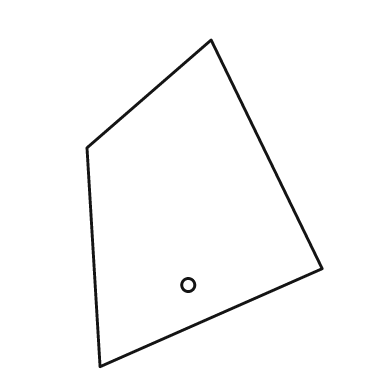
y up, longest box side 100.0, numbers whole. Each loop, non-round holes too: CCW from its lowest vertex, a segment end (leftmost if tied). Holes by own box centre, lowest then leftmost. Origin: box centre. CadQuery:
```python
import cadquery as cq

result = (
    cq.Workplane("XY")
    .moveTo(-32.0, -50.0)
    .lineTo(36.0, -20.0)
    .lineTo(2.0, 50.0)
    .lineTo(-36.0, 17.0)
    .close()
    .moveTo(-5.0, -25.0)
    .circle(2.0)
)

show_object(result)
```